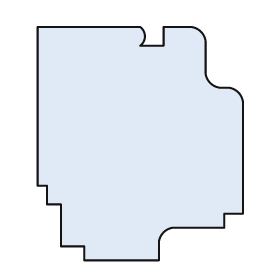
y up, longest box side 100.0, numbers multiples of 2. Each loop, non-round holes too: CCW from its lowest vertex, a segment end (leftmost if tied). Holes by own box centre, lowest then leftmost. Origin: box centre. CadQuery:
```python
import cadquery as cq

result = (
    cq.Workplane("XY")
    .moveTo(-24.0, -50.0)
    .lineTo(8.0, -50.0)
    .lineTo(8.0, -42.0)
    .threePointArc((10.0, -38.0), (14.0, -36.0))
    .lineTo(36.0, -36.0)
    .lineTo(36.0, -30.0)
    .lineTo(44.0, -30.0)
    .lineTo(44.0, 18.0)
    .threePointArc((42.0, 22.0), (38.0, 24.0))
    .lineTo(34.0, 24.0)
    .threePointArc((30.0, 26.0), (28.0, 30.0))
    .lineTo(28.0, 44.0)
    .threePointArc((26.0, 48.0), (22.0, 50.0))
    .lineTo(10.0, 50.0)
    .lineTo(10.0, 42.0)
    .lineTo(0.0, 42.0)
    .threePointArc((2.0, 46.0), (0.0, 50.0))
    .lineTo(-44.0, 50.0)
    .lineTo(-44.0, -18.0)
    .lineTo(-40.0, -18.0)
    .lineTo(-40.0, -26.0)
    .lineTo(-34.0, -26.0)
    .lineTo(-34.0, -44.0)
    .lineTo(-24.0, -44.0)
    .close()
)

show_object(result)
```